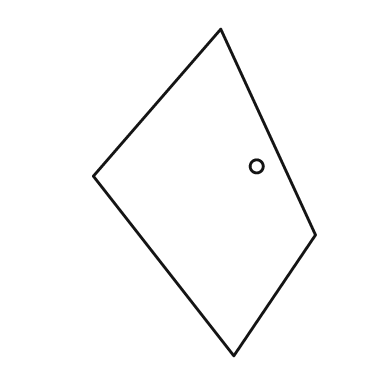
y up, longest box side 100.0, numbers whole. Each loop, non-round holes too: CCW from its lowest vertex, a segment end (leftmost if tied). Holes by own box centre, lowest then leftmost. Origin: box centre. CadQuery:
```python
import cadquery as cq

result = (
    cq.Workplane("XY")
    .moveTo(9.0, -50.0)
    .lineTo(34.0, -13.0)
    .lineTo(5.0, 50.0)
    .lineTo(-34.0, 5.0)
    .close()
    .moveTo(16.0, 8.0)
    .circle(2.0)
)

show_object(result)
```